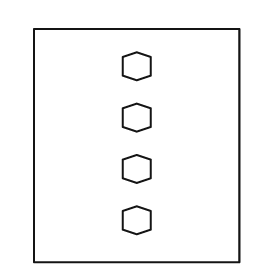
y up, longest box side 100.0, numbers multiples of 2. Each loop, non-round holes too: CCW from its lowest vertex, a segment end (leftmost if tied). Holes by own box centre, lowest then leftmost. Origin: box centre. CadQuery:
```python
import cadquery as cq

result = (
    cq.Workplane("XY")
    .moveTo(-44.0, -50.0)
    .lineTo(44.0, -50.0)
    .lineTo(44.0, 50.0)
    .lineTo(-44.0, 50.0)
    .close()
    .moveTo(0.0, -38.0)
    .lineTo(6.0, -36.0)
    .lineTo(6.0, -28.0)
    .lineTo(0.0, -26.0)
    .lineTo(-6.0, -28.0)
    .lineTo(-6.0, -36.0)
    .close()
    .moveTo(0.0, -16.0)
    .lineTo(6.0, -14.0)
    .lineTo(6.0, -6.0)
    .lineTo(0.0, -4.0)
    .lineTo(-6.0, -6.0)
    .lineTo(-6.0, -14.0)
    .close()
    .moveTo(0.0, 6.0)
    .lineTo(6.0, 8.0)
    .lineTo(6.0, 16.0)
    .lineTo(0.0, 18.0)
    .lineTo(-6.0, 16.0)
    .lineTo(-6.0, 8.0)
    .close()
    .moveTo(0.0, 28.0)
    .lineTo(6.0, 30.0)
    .lineTo(6.0, 38.0)
    .lineTo(0.0, 40.0)
    .lineTo(-6.0, 38.0)
    .lineTo(-6.0, 30.0)
    .close()
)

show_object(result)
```